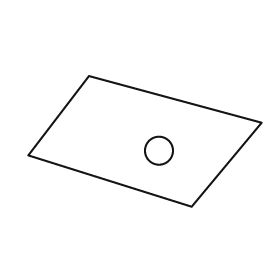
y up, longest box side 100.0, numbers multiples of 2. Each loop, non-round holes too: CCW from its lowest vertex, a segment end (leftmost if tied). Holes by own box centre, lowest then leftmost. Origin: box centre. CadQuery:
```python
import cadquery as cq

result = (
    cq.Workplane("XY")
    .moveTo(20.0, -28.0)
    .lineTo(50.0, 8.0)
    .lineTo(-24.0, 28.0)
    .lineTo(-50.0, -6.0)
    .close()
    .moveTo(6.0, -4.0)
    .circle(6.0)
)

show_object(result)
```